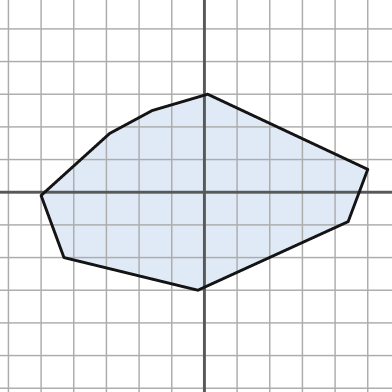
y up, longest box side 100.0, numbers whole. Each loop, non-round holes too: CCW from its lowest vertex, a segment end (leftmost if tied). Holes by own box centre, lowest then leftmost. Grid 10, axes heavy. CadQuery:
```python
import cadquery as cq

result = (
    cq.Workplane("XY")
    .moveTo(-2.0, -30.0)
    .lineTo(44.0, -9.0)
    .lineTo(50.0, 7.0)
    .lineTo(1.0, 30.0)
    .lineTo(-16.0, 25.0)
    .lineTo(-29.0, 18.0)
    .lineTo(-50.0, -1.0)
    .lineTo(-43.0, -20.0)
    .close()
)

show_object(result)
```